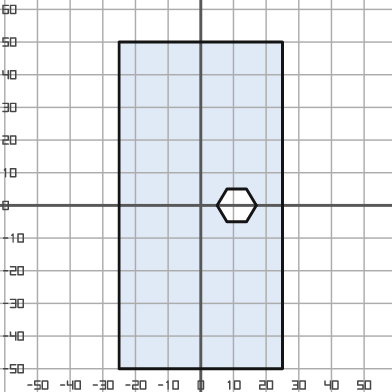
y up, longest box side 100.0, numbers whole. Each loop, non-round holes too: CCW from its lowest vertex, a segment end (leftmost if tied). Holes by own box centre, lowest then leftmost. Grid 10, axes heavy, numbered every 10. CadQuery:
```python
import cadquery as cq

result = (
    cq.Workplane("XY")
    .moveTo(-25.0, -50.0)
    .lineTo(25.0, -50.0)
    .lineTo(25.0, 50.0)
    .lineTo(-25.0, 50.0)
    .close()
    .moveTo(8.0, -5.0)
    .lineTo(14.0, -5.0)
    .lineTo(17.0, 0.0)
    .lineTo(14.0, 5.0)
    .lineTo(8.0, 5.0)
    .lineTo(5.0, 0.0)
    .close()
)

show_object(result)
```